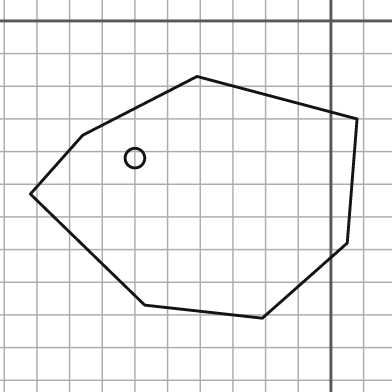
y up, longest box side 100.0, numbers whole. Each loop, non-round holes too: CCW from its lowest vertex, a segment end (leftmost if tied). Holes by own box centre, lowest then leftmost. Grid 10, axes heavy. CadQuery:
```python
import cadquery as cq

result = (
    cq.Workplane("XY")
    .moveTo(-21.0, -91.0)
    .lineTo(5.0, -68.0)
    .lineTo(8.0, -30.0)
    .lineTo(-41.0, -17.0)
    .lineTo(-76.0, -35.0)
    .lineTo(-92.0, -53.0)
    .lineTo(-57.0, -87.0)
    .close()
    .moveTo(-60.0, -42.0)
    .circle(3.0)
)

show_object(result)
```